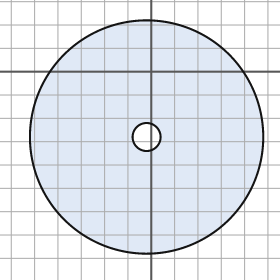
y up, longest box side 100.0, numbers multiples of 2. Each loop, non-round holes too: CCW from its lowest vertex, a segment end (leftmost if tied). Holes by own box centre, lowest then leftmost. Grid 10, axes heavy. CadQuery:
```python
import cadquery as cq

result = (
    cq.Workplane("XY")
    .moveTo(-2.0, -28.0)
    .circle(50.0)
    .moveTo(-2.0, -28.0)
    .circle(6.0)
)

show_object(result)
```